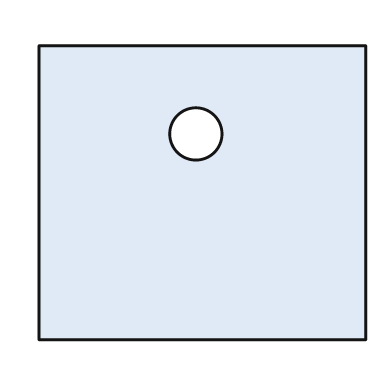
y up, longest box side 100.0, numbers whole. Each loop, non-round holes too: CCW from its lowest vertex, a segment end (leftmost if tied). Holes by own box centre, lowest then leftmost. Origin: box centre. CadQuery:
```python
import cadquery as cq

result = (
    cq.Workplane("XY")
    .moveTo(-50.0, -45.0)
    .lineTo(50.0, -45.0)
    .lineTo(50.0, 45.0)
    .lineTo(-50.0, 45.0)
    .close()
    .moveTo(-2.0, 18.0)
    .circle(8.0)
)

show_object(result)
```